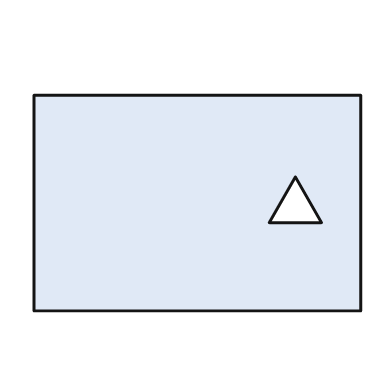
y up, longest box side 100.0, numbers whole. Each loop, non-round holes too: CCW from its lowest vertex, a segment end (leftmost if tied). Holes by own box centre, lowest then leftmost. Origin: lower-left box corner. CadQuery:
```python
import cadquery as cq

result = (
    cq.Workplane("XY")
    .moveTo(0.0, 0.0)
    .lineTo(100.0, 0.0)
    .lineTo(100.0, 66.0)
    .lineTo(0.0, 66.0)
    .close()
    .moveTo(72.0, 27.0)
    .lineTo(88.0, 27.0)
    .lineTo(80.0, 41.0)
    .close()
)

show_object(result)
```